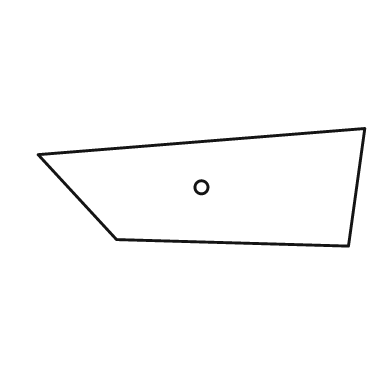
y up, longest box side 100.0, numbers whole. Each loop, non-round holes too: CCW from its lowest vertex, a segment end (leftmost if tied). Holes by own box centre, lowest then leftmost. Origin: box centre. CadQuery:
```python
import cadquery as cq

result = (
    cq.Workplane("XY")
    .moveTo(45.0, -18.0)
    .lineTo(50.0, 18.0)
    .lineTo(-50.0, 10.0)
    .lineTo(-26.0, -16.0)
    .close()
    .moveTo(0.0, 0.0)
    .circle(2.0)
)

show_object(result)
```